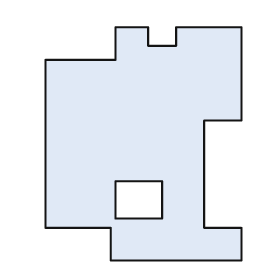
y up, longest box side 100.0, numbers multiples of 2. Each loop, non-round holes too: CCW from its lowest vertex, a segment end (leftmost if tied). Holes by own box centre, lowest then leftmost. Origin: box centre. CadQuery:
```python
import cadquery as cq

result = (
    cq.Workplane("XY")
    .moveTo(-14.0, -50.0)
    .lineTo(42.0, -50.0)
    .lineTo(42.0, -36.0)
    .lineTo(26.0, -36.0)
    .lineTo(26.0, 10.0)
    .lineTo(42.0, 10.0)
    .lineTo(42.0, 50.0)
    .lineTo(14.0, 50.0)
    .lineTo(14.0, 42.0)
    .lineTo(2.0, 42.0)
    .lineTo(2.0, 50.0)
    .lineTo(-12.0, 50.0)
    .lineTo(-12.0, 36.0)
    .lineTo(-42.0, 36.0)
    .lineTo(-42.0, -36.0)
    .lineTo(-14.0, -36.0)
    .close()
    .moveTo(-12.0, -32.0)
    .lineTo(8.0, -32.0)
    .lineTo(8.0, -16.0)
    .lineTo(-12.0, -16.0)
    .close()
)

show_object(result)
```